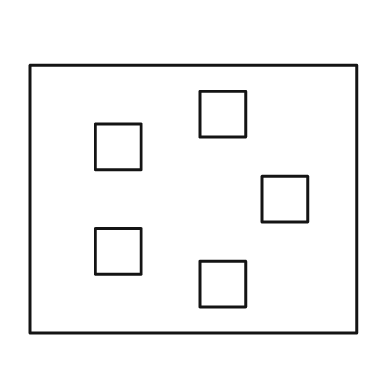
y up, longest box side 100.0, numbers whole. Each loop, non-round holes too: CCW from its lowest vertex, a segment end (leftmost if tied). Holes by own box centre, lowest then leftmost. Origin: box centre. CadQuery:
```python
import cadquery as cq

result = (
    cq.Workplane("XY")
    .moveTo(-50.0, -41.0)
    .lineTo(50.0, -41.0)
    .lineTo(50.0, 41.0)
    .lineTo(-50.0, 41.0)
    .close()
    .moveTo(2.0, -33.0)
    .lineTo(16.0, -33.0)
    .lineTo(16.0, -19.0)
    .lineTo(2.0, -19.0)
    .close()
    .moveTo(-30.0, -23.0)
    .lineTo(-16.0, -23.0)
    .lineTo(-16.0, -9.0)
    .lineTo(-30.0, -9.0)
    .close()
    .moveTo(21.0, -7.0)
    .lineTo(35.0, -7.0)
    .lineTo(35.0, 7.0)
    .lineTo(21.0, 7.0)
    .close()
    .moveTo(-30.0, 9.0)
    .lineTo(-16.0, 9.0)
    .lineTo(-16.0, 23.0)
    .lineTo(-30.0, 23.0)
    .close()
    .moveTo(2.0, 19.0)
    .lineTo(16.0, 19.0)
    .lineTo(16.0, 33.0)
    .lineTo(2.0, 33.0)
    .close()
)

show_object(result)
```